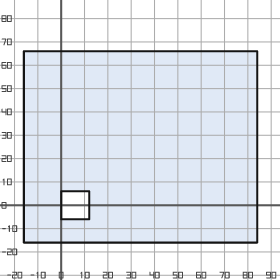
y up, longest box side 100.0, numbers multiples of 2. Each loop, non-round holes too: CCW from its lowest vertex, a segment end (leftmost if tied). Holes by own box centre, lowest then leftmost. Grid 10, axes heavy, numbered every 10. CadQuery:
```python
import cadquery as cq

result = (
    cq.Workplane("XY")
    .moveTo(-16.0, -16.0)
    .lineTo(84.0, -16.0)
    .lineTo(84.0, 66.0)
    .lineTo(-16.0, 66.0)
    .close()
    .moveTo(0.0, -6.0)
    .lineTo(12.0, -6.0)
    .lineTo(12.0, 6.0)
    .lineTo(0.0, 6.0)
    .close()
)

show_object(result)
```